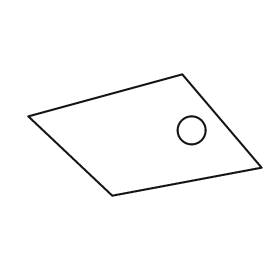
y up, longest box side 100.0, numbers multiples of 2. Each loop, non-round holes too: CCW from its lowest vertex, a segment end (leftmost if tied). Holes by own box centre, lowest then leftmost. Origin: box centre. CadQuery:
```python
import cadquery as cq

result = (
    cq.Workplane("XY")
    .moveTo(-14.0, -26.0)
    .lineTo(50.0, -14.0)
    .lineTo(16.0, 26.0)
    .lineTo(-50.0, 8.0)
    .close()
    .moveTo(20.0, 2.0)
    .circle(6.0)
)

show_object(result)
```